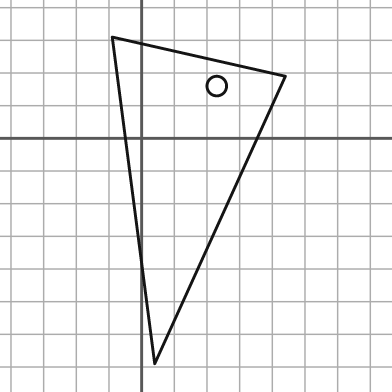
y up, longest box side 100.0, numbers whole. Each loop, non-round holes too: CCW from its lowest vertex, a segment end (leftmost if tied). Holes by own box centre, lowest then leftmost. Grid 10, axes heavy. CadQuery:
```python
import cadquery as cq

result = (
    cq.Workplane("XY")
    .moveTo(4.0, -69.0)
    .lineTo(44.0, 19.0)
    .lineTo(-9.0, 31.0)
    .close()
    .moveTo(23.0, 16.0)
    .circle(3.0)
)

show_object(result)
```